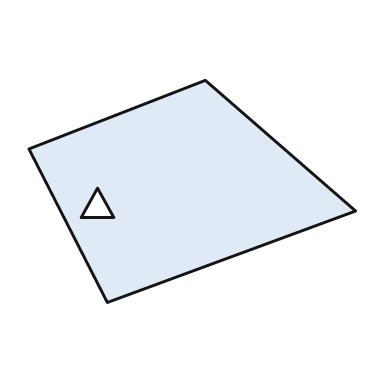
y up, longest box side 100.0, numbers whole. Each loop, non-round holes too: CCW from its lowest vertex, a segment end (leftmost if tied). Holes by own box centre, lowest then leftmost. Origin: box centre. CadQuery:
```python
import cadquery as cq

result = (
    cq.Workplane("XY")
    .moveTo(-26.0, -34.0)
    .lineTo(50.0, -6.0)
    .lineTo(4.0, 34.0)
    .lineTo(-50.0, 13.0)
    .close()
    .moveTo(-34.0, -8.0)
    .lineTo(-24.0, -8.0)
    .lineTo(-29.0, 1.0)
    .close()
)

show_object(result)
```